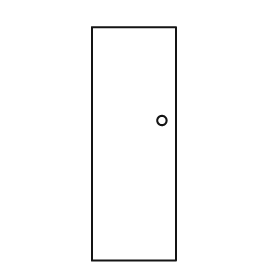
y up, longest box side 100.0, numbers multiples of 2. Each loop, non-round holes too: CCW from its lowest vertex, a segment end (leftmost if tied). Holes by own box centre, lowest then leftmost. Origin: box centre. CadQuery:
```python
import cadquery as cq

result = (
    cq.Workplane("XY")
    .moveTo(-18.0, -50.0)
    .lineTo(18.0, -50.0)
    .lineTo(18.0, 50.0)
    .lineTo(-18.0, 50.0)
    .close()
    .moveTo(12.0, 10.0)
    .circle(2.0)
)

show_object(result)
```